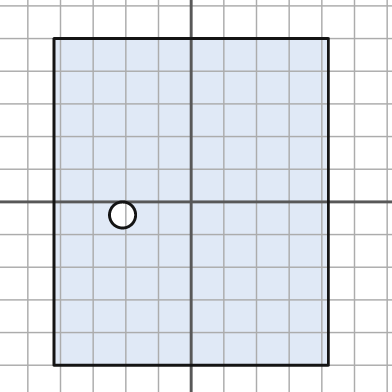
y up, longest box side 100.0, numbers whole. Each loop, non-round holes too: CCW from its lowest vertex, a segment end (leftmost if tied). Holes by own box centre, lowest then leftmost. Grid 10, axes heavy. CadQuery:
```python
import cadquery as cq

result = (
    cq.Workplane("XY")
    .moveTo(-42.0, -50.0)
    .lineTo(42.0, -50.0)
    .lineTo(42.0, 50.0)
    .lineTo(-42.0, 50.0)
    .close()
    .moveTo(-21.0, -4.0)
    .circle(4.0)
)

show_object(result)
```